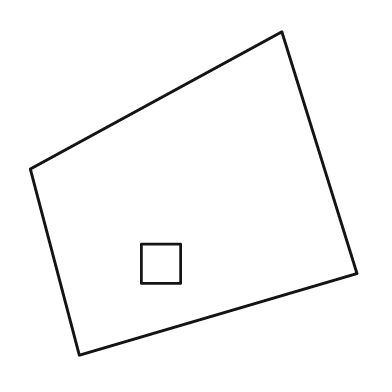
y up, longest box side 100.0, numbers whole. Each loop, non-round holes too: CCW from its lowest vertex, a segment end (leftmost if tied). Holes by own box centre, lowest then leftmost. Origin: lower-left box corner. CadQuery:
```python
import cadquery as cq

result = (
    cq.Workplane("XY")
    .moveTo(15.0, 0.0)
    .lineTo(100.0, 25.0)
    .lineTo(77.0, 99.0)
    .lineTo(0.0, 57.0)
    .close()
    .moveTo(34.0, 22.0)
    .lineTo(46.0, 22.0)
    .lineTo(46.0, 34.0)
    .lineTo(34.0, 34.0)
    .close()
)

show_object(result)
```